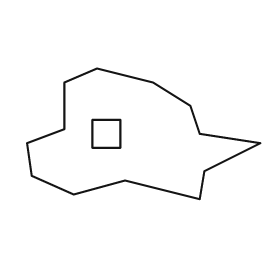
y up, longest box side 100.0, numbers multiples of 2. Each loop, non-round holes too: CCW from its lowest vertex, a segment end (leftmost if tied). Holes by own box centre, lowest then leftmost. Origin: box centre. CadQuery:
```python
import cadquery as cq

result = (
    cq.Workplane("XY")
    .moveTo(24.0, -28.0)
    .lineTo(26.0, -16.0)
    .lineTo(50.0, -4.0)
    .lineTo(24.0, 0.0)
    .lineTo(20.0, 12.0)
    .lineTo(4.0, 22.0)
    .lineTo(-20.0, 28.0)
    .lineTo(-34.0, 22.0)
    .lineTo(-34.0, 2.0)
    .lineTo(-50.0, -4.0)
    .lineTo(-48.0, -18.0)
    .lineTo(-30.0, -26.0)
    .lineTo(-8.0, -20.0)
    .close()
    .moveTo(-22.0, -6.0)
    .lineTo(-10.0, -6.0)
    .lineTo(-10.0, 6.0)
    .lineTo(-22.0, 6.0)
    .close()
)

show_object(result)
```